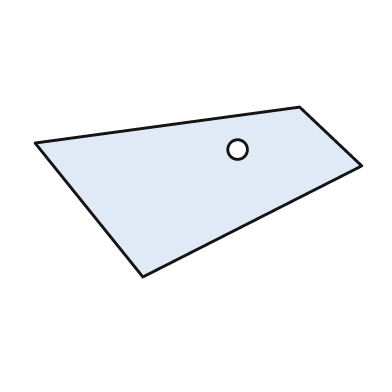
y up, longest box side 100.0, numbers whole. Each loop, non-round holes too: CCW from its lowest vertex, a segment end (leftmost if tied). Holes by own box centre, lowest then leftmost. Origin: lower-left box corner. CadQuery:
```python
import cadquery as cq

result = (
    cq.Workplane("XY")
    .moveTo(33.0, 0.0)
    .lineTo(100.0, 34.0)
    .lineTo(81.0, 52.0)
    .lineTo(0.0, 41.0)
    .close()
    .moveTo(62.0, 39.0)
    .circle(3.0)
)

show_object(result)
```